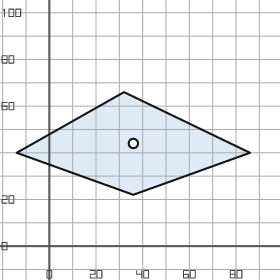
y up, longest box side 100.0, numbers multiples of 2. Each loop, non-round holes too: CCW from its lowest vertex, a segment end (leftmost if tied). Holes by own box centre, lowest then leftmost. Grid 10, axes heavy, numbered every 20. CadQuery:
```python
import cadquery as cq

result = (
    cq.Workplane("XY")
    .moveTo(36.0, 22.0)
    .lineTo(86.0, 40.0)
    .lineTo(32.0, 66.0)
    .lineTo(-14.0, 40.0)
    .close()
    .moveTo(36.0, 44.0)
    .circle(2.0)
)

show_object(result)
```